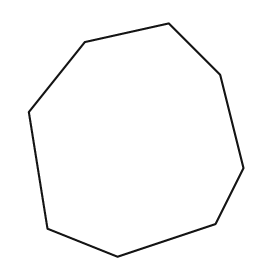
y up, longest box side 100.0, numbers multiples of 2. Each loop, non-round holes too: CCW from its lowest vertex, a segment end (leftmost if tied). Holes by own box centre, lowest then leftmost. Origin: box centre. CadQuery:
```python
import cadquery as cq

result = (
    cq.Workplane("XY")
    .moveTo(-8.0, -50.0)
    .lineTo(34.0, -36.0)
    .lineTo(46.0, -12.0)
    .lineTo(36.0, 28.0)
    .lineTo(14.0, 50.0)
    .lineTo(-22.0, 42.0)
    .lineTo(-46.0, 12.0)
    .lineTo(-38.0, -38.0)
    .close()
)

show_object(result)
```